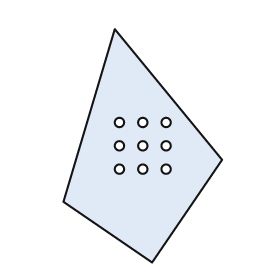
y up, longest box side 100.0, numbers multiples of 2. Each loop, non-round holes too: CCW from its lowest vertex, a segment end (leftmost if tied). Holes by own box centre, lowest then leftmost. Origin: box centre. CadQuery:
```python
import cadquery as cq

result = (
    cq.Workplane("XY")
    .moveTo(4.0, -50.0)
    .lineTo(34.0, -6.0)
    .lineTo(-12.0, 50.0)
    .lineTo(-34.0, -24.0)
    .close()
    .moveTo(-10.0, -10.0)
    .circle(2.0)
    .moveTo(0.0, -10.0)
    .circle(2.0)
    .moveTo(10.0, -10.0)
    .circle(2.0)
    .moveTo(-10.0, 0.0)
    .circle(2.0)
    .moveTo(0.0, 0.0)
    .circle(2.0)
    .moveTo(10.0, 0.0)
    .circle(2.0)
    .moveTo(-10.0, 10.0)
    .circle(2.0)
    .moveTo(0.0, 10.0)
    .circle(2.0)
    .moveTo(10.0, 10.0)
    .circle(2.0)
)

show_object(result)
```